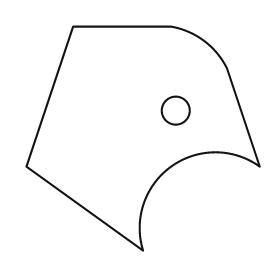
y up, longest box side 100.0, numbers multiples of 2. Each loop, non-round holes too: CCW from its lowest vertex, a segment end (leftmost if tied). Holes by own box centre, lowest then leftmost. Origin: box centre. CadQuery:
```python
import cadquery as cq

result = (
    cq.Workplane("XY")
    .moveTo(0.0, -48.0)
    .threePointArc((12.0, -12.0), (50.0, -12.0))
    .lineTo(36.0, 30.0)
    .threePointArc((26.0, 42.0), (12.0, 48.0))
    .lineTo(-30.0, 48.0)
    .lineTo(-50.0, -12.0)
    .close()
    .moveTo(14.0, 12.0)
    .circle(6.0)
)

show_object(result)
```